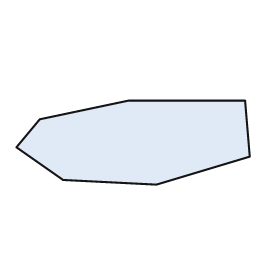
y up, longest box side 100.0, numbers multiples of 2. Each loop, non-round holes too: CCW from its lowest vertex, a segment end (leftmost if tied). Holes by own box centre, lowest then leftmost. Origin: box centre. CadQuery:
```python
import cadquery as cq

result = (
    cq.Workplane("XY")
    .moveTo(10.0, -18.0)
    .lineTo(50.0, -6.0)
    .lineTo(48.0, 18.0)
    .lineTo(-2.0, 18.0)
    .lineTo(-40.0, 10.0)
    .lineTo(-50.0, -2.0)
    .lineTo(-30.0, -16.0)
    .close()
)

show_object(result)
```